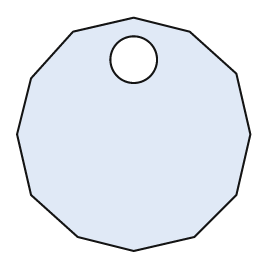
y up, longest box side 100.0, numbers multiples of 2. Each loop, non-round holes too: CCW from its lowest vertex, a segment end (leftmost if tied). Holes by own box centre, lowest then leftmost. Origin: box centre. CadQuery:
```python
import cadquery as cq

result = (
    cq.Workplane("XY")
    .moveTo(0.0, -50.0)
    .lineTo(26.0, -44.0)
    .lineTo(44.0, -26.0)
    .lineTo(50.0, 0.0)
    .lineTo(44.0, 26.0)
    .lineTo(24.0, 44.0)
    .lineTo(0.0, 50.0)
    .lineTo(-26.0, 44.0)
    .lineTo(-44.0, 24.0)
    .lineTo(-50.0, 0.0)
    .lineTo(-44.0, -26.0)
    .lineTo(-24.0, -44.0)
    .close()
    .moveTo(0.0, 32.0)
    .circle(10.0)
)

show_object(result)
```